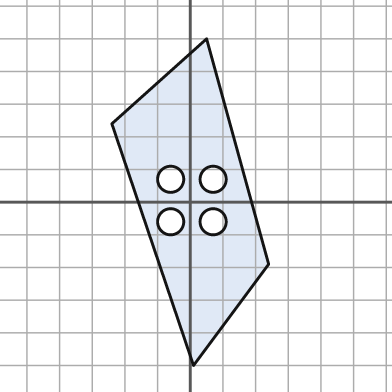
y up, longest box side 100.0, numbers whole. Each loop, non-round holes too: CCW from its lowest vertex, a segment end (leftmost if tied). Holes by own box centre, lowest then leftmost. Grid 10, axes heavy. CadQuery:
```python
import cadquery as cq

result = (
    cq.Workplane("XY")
    .moveTo(1.0, -50.0)
    .lineTo(24.0, -19.0)
    .lineTo(5.0, 50.0)
    .lineTo(-24.0, 24.0)
    .close()
    .moveTo(-6.0, -6.0)
    .circle(4.0)
    .moveTo(7.0, -6.0)
    .circle(4.0)
    .moveTo(-6.0, 7.0)
    .circle(4.0)
    .moveTo(7.0, 7.0)
    .circle(4.0)
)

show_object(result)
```